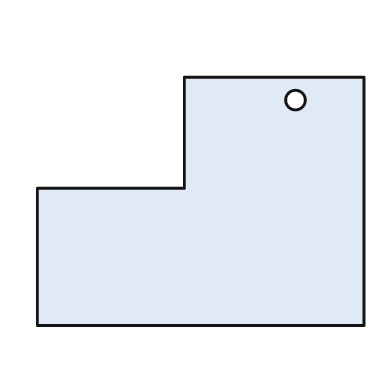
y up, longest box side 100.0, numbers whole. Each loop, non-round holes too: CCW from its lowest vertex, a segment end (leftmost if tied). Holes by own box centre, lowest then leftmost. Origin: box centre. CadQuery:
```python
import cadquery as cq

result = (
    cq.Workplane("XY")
    .moveTo(-50.0, -38.0)
    .lineTo(50.0, -38.0)
    .lineTo(50.0, 38.0)
    .lineTo(-5.0, 38.0)
    .lineTo(-5.0, 4.0)
    .lineTo(-50.0, 4.0)
    .close()
    .moveTo(29.0, 31.0)
    .circle(3.0)
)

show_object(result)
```